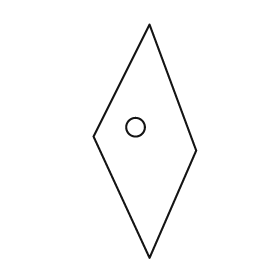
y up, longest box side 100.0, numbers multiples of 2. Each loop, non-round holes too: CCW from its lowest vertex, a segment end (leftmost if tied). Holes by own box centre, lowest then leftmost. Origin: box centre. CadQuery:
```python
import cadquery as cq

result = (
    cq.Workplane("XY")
    .moveTo(2.0, -50.0)
    .lineTo(22.0, -4.0)
    .lineTo(2.0, 50.0)
    .lineTo(-22.0, 2.0)
    .close()
    .moveTo(-4.0, 6.0)
    .circle(4.0)
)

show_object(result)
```